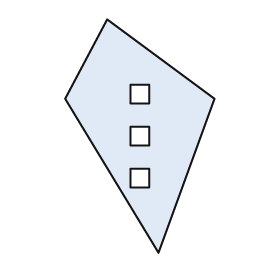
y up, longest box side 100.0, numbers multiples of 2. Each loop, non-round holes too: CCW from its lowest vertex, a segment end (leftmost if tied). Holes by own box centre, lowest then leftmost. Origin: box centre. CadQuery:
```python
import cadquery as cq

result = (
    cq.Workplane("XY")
    .moveTo(8.0, -50.0)
    .lineTo(32.0, 16.0)
    .lineTo(-14.0, 50.0)
    .lineTo(-32.0, 16.0)
    .close()
    .moveTo(-4.0, -22.0)
    .lineTo(4.0, -22.0)
    .lineTo(4.0, -14.0)
    .lineTo(-4.0, -14.0)
    .close()
    .moveTo(-4.0, -4.0)
    .lineTo(4.0, -4.0)
    .lineTo(4.0, 4.0)
    .lineTo(-4.0, 4.0)
    .close()
    .moveTo(-4.0, 14.0)
    .lineTo(4.0, 14.0)
    .lineTo(4.0, 22.0)
    .lineTo(-4.0, 22.0)
    .close()
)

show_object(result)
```